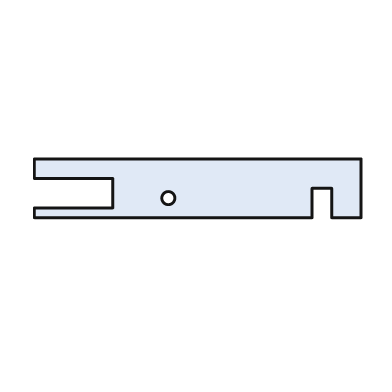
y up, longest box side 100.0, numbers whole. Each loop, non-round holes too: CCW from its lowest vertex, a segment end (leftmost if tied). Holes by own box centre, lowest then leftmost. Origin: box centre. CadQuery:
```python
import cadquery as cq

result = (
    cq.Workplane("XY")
    .moveTo(-50.0, -9.0)
    .lineTo(35.0, -9.0)
    .lineTo(35.0, 0.0)
    .lineTo(41.0, 0.0)
    .lineTo(41.0, -9.0)
    .lineTo(50.0, -9.0)
    .lineTo(50.0, 9.0)
    .lineTo(-50.0, 9.0)
    .lineTo(-50.0, 3.0)
    .lineTo(-26.0, 3.0)
    .lineTo(-26.0, -6.0)
    .lineTo(-50.0, -6.0)
    .close()
    .moveTo(-9.0, -3.0)
    .circle(2.0)
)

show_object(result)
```